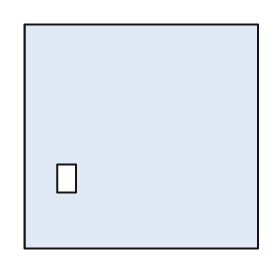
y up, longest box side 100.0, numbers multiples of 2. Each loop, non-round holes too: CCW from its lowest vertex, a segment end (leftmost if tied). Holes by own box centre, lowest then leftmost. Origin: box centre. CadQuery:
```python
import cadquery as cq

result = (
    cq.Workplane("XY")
    .moveTo(-50.0, -48.0)
    .lineTo(50.0, -48.0)
    .lineTo(50.0, 48.0)
    .lineTo(-50.0, 48.0)
    .close()
    .moveTo(-36.0, -24.0)
    .lineTo(-28.0, -24.0)
    .lineTo(-28.0, -12.0)
    .lineTo(-36.0, -12.0)
    .close()
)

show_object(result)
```